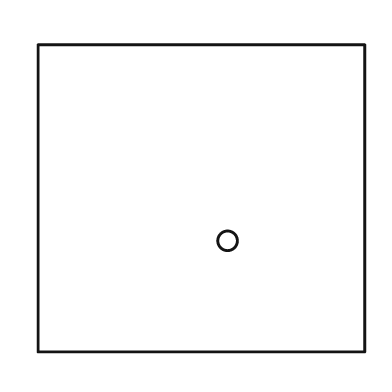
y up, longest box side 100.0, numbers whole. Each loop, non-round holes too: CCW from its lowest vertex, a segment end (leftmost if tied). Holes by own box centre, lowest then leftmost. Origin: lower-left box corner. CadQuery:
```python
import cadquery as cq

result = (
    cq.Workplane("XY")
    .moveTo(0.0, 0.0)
    .lineTo(100.0, 0.0)
    .lineTo(100.0, 94.0)
    .lineTo(0.0, 94.0)
    .close()
    .moveTo(58.0, 34.0)
    .circle(3.0)
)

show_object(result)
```